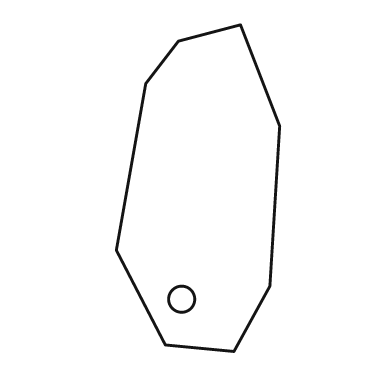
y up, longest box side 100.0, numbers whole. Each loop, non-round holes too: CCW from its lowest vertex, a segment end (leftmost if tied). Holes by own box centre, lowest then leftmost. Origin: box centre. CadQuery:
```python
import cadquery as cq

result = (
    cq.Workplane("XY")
    .moveTo(11.0, -50.0)
    .lineTo(22.0, -30.0)
    .lineTo(25.0, 19.0)
    .lineTo(13.0, 50.0)
    .lineTo(-6.0, 45.0)
    .lineTo(-16.0, 32.0)
    .lineTo(-25.0, -19.0)
    .lineTo(-10.0, -48.0)
    .close()
    .moveTo(-5.0, -34.0)
    .circle(4.0)
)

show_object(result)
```